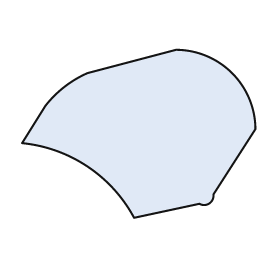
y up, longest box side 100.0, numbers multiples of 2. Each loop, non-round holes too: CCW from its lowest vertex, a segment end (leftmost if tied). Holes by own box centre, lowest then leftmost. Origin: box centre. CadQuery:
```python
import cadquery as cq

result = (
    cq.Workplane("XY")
    .moveTo(-2.0, -36.0)
    .lineTo(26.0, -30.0)
    .threePointArc((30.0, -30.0), (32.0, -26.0))
    .lineTo(50.0, 2.0)
    .threePointArc((40.0, 26.0), (16.0, 36.0))
    .lineTo(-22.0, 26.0)
    .threePointArc((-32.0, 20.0), (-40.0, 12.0))
    .lineTo(-50.0, -4.0)
    .threePointArc((-22.0, -14.0), (-2.0, -36.0))
    .close()
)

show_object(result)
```